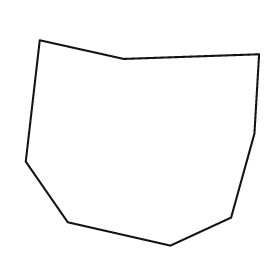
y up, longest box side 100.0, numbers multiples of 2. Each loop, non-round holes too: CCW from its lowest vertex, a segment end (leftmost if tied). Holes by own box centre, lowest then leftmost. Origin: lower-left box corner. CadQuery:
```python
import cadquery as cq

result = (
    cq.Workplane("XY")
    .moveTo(62.0, 0.0)
    .lineTo(88.0, 12.0)
    .lineTo(98.0, 48.0)
    .lineTo(100.0, 82.0)
    .lineTo(42.0, 80.0)
    .lineTo(6.0, 88.0)
    .lineTo(0.0, 36.0)
    .lineTo(18.0, 10.0)
    .close()
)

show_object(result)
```